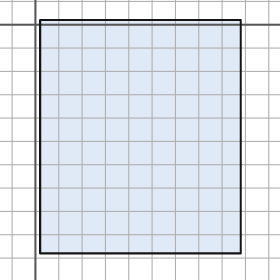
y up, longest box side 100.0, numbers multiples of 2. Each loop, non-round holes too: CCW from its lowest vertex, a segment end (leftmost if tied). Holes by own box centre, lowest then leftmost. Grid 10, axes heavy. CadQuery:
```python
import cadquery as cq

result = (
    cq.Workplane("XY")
    .moveTo(2.0, -98.0)
    .lineTo(88.0, -98.0)
    .lineTo(88.0, 2.0)
    .lineTo(2.0, 2.0)
    .close()
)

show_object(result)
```